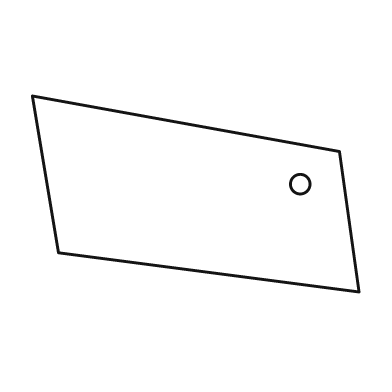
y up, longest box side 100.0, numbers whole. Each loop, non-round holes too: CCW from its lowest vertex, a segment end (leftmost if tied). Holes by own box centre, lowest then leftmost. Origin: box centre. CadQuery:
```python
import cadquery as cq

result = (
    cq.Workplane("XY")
    .moveTo(50.0, -30.0)
    .lineTo(44.0, 13.0)
    .lineTo(-50.0, 30.0)
    .lineTo(-42.0, -18.0)
    .close()
    .moveTo(32.0, 3.0)
    .circle(3.0)
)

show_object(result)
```